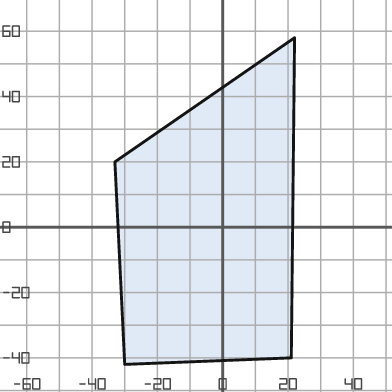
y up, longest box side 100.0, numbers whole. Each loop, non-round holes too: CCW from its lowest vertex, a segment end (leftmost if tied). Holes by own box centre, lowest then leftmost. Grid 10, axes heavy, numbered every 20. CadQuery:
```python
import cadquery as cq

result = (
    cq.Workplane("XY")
    .moveTo(-30.0, -42.0)
    .lineTo(21.0, -40.0)
    .lineTo(22.0, 58.0)
    .lineTo(-33.0, 20.0)
    .close()
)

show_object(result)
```